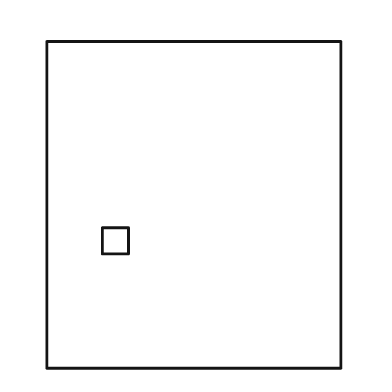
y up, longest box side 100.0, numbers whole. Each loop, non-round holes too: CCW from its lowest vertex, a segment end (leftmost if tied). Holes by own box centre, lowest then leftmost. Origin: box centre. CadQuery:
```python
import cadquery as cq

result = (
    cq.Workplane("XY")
    .moveTo(-45.0, -50.0)
    .lineTo(45.0, -50.0)
    .lineTo(45.0, 50.0)
    .lineTo(-45.0, 50.0)
    .close()
    .moveTo(-28.0, -15.0)
    .lineTo(-20.0, -15.0)
    .lineTo(-20.0, -7.0)
    .lineTo(-28.0, -7.0)
    .close()
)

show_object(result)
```